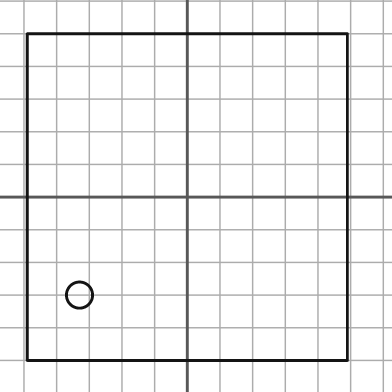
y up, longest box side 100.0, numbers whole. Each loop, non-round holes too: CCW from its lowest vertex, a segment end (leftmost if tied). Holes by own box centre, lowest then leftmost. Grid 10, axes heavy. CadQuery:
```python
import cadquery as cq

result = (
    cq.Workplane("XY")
    .moveTo(-49.0, -50.0)
    .lineTo(49.0, -50.0)
    .lineTo(49.0, 50.0)
    .lineTo(-49.0, 50.0)
    .close()
    .moveTo(-33.0, -30.0)
    .circle(4.0)
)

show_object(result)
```